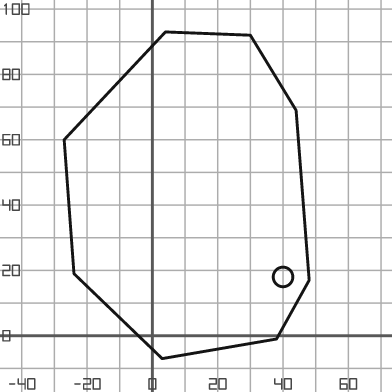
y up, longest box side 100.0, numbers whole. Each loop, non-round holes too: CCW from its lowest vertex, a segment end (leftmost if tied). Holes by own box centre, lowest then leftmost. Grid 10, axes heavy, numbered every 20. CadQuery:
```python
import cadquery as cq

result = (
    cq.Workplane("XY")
    .moveTo(3.0, -7.0)
    .lineTo(38.0, -1.0)
    .lineTo(48.0, 17.0)
    .lineTo(44.0, 69.0)
    .lineTo(30.0, 92.0)
    .lineTo(4.0, 93.0)
    .lineTo(-27.0, 60.0)
    .lineTo(-24.0, 19.0)
    .close()
    .moveTo(40.0, 18.0)
    .circle(3.0)
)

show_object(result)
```